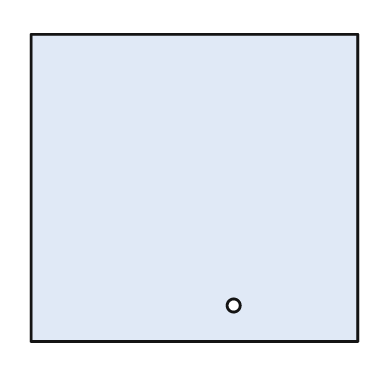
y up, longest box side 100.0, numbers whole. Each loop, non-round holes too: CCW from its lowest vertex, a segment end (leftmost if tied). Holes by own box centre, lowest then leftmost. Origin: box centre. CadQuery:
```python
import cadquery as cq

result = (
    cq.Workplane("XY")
    .moveTo(-50.0, -47.0)
    .lineTo(50.0, -47.0)
    .lineTo(50.0, 47.0)
    .lineTo(-50.0, 47.0)
    .close()
    .moveTo(12.0, -36.0)
    .circle(2.0)
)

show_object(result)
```